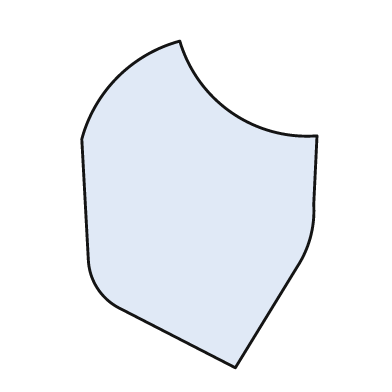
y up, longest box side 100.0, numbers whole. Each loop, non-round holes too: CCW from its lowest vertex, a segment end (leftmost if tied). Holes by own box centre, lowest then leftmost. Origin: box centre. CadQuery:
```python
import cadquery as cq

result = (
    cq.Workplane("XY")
    .moveTo(11.0, -50.0)
    .lineTo(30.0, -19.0)
    .threePointArc((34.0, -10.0), (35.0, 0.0))
    .lineTo(36.0, 21.0)
    .threePointArc((10.0, 28.0), (-6.0, 50.0))
    .threePointArc((-25.0, 39.0), (-36.0, 20.0))
    .lineTo(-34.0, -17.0)
    .threePointArc((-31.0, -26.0), (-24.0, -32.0))
    .close()
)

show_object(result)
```